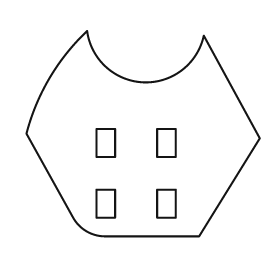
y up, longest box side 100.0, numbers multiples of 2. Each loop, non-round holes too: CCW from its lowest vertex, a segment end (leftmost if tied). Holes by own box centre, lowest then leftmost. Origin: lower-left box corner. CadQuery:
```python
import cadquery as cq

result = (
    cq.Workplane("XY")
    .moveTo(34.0, 0.0)
    .lineTo(74.0, 0.0)
    .lineTo(100.0, 42.0)
    .lineTo(76.0, 86.0)
    .threePointArc((50.0, 66.0), (26.0, 88.0))
    .threePointArc((10.0, 68.0), (0.0, 44.0))
    .lineTo(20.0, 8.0)
    .threePointArc((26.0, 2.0), (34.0, 0.0))
    .close()
    .moveTo(30.0, 8.0)
    .lineTo(38.0, 8.0)
    .lineTo(38.0, 20.0)
    .lineTo(30.0, 20.0)
    .close()
    .moveTo(56.0, 8.0)
    .lineTo(64.0, 8.0)
    .lineTo(64.0, 20.0)
    .lineTo(56.0, 20.0)
    .close()
    .moveTo(30.0, 34.0)
    .lineTo(38.0, 34.0)
    .lineTo(38.0, 46.0)
    .lineTo(30.0, 46.0)
    .close()
    .moveTo(56.0, 34.0)
    .lineTo(64.0, 34.0)
    .lineTo(64.0, 46.0)
    .lineTo(56.0, 46.0)
    .close()
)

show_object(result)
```